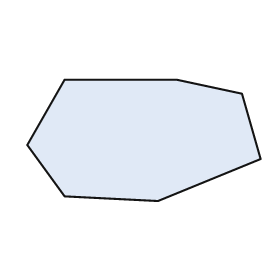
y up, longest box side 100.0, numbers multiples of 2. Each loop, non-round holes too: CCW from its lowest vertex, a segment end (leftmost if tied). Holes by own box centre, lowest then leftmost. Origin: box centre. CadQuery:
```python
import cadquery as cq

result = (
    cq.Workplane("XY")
    .moveTo(6.0, -26.0)
    .lineTo(50.0, -8.0)
    .lineTo(42.0, 20.0)
    .lineTo(14.0, 26.0)
    .lineTo(-34.0, 26.0)
    .lineTo(-50.0, -2.0)
    .lineTo(-34.0, -24.0)
    .close()
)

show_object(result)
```